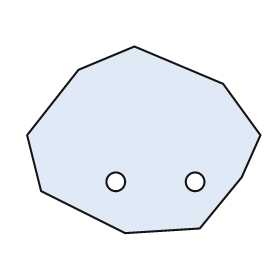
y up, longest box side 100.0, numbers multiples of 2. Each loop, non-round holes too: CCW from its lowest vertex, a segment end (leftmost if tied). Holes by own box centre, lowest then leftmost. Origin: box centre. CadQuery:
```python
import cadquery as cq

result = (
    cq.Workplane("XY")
    .moveTo(-8.0, -40.0)
    .lineTo(24.0, -38.0)
    .lineTo(42.0, -16.0)
    .lineTo(50.0, 2.0)
    .lineTo(34.0, 24.0)
    .lineTo(-4.0, 40.0)
    .lineTo(-28.0, 30.0)
    .lineTo(-50.0, 2.0)
    .lineTo(-44.0, -22.0)
    .close()
    .moveTo(-12.0, -18.0)
    .circle(4.0)
    .moveTo(22.0, -18.0)
    .circle(4.0)
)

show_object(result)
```